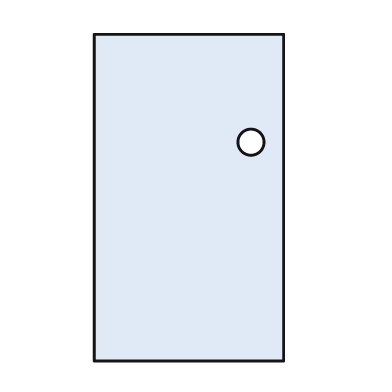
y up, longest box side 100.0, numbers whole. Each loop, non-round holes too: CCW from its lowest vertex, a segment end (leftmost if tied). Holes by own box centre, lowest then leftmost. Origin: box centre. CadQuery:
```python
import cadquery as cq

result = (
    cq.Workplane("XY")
    .moveTo(-29.0, -50.0)
    .lineTo(29.0, -50.0)
    .lineTo(29.0, 50.0)
    .lineTo(-29.0, 50.0)
    .close()
    .moveTo(19.0, 17.0)
    .circle(4.0)
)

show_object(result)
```